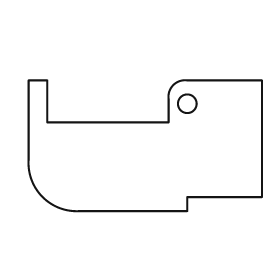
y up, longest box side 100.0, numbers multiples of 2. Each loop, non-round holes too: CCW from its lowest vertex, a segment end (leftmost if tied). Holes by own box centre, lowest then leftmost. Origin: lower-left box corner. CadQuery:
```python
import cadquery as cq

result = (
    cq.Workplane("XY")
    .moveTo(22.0, 0.0)
    .lineTo(68.0, 0.0)
    .lineTo(68.0, 6.0)
    .lineTo(100.0, 6.0)
    .lineTo(100.0, 56.0)
    .lineTo(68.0, 56.0)
    .threePointArc((62.0, 54.0), (60.0, 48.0))
    .lineTo(60.0, 38.0)
    .lineTo(8.0, 38.0)
    .lineTo(8.0, 56.0)
    .lineTo(0.0, 56.0)
    .lineTo(0.0, 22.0)
    .threePointArc((6.0, 6.0), (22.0, 0.0))
    .close()
    .moveTo(68.0, 46.0)
    .circle(4.0)
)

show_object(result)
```